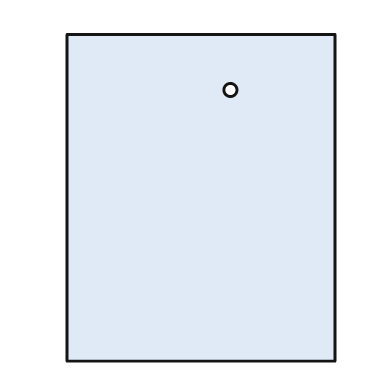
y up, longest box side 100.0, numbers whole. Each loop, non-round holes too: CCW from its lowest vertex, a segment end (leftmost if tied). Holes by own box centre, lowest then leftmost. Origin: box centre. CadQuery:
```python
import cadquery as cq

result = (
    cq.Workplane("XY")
    .moveTo(-41.0, -50.0)
    .lineTo(41.0, -50.0)
    .lineTo(41.0, 50.0)
    .lineTo(-41.0, 50.0)
    .close()
    .moveTo(9.0, 33.0)
    .circle(2.0)
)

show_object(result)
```